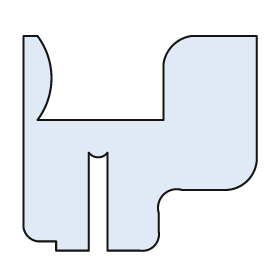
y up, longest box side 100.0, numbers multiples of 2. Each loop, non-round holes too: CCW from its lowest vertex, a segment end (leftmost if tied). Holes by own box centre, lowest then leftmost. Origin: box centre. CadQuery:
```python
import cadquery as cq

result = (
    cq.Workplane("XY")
    .moveTo(-36.0, -46.0)
    .lineTo(-22.0, -46.0)
    .lineTo(-22.0, -4.0)
    .threePointArc((-18.0, -6.0), (-14.0, -4.0))
    .lineTo(-14.0, -46.0)
    .lineTo(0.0, -46.0)
    .threePointArc((6.0, -44.0), (8.0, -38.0))
    .lineTo(8.0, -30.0)
    .threePointArc((10.0, -22.0), (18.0, -20.0))
    .lineTo(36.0, -20.0)
    .threePointArc((46.0, -16.0), (50.0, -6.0))
    .lineTo(50.0, 46.0)
    .lineTo(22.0, 46.0)
    .threePointArc((14.0, 42.0), (10.0, 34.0))
    .lineTo(10.0, 10.0)
    .lineTo(-44.0, 10.0)
    .threePointArc((-38.0, 28.0), (-44.0, 46.0))
    .lineTo(-50.0, 46.0)
    .lineTo(-50.0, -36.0)
    .threePointArc((-48.0, -40.0), (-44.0, -42.0))
    .lineTo(-36.0, -42.0)
    .close()
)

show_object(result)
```